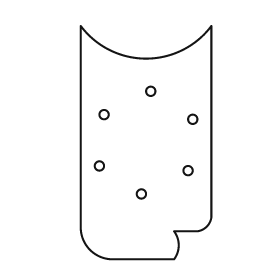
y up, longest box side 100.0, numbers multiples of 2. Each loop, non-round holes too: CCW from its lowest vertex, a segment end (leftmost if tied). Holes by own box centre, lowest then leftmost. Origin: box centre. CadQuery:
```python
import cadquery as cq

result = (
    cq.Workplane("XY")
    .moveTo(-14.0, -50.0)
    .lineTo(12.0, -50.0)
    .threePointArc((14.0, -44.0), (12.0, -38.0))
    .lineTo(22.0, -38.0)
    .threePointArc((26.0, -36.0), (28.0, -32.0))
    .lineTo(28.0, 50.0)
    .threePointArc((0.0, 36.0), (-28.0, 50.0))
    .lineTo(-28.0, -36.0)
    .threePointArc((-24.0, -46.0), (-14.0, -50.0))
    .close()
    .moveTo(-2.0, -22.0)
    .circle(2.0)
    .moveTo(18.0, -12.0)
    .circle(2.0)
    .moveTo(-20.0, -10.0)
    .circle(2.0)
    .moveTo(20.0, 10.0)
    .circle(2.0)
    .moveTo(-18.0, 12.0)
    .circle(2.0)
    .moveTo(2.0, 22.0)
    .circle(2.0)
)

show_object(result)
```